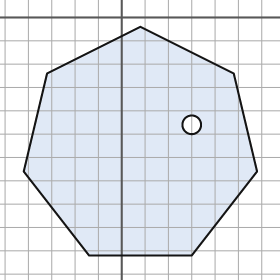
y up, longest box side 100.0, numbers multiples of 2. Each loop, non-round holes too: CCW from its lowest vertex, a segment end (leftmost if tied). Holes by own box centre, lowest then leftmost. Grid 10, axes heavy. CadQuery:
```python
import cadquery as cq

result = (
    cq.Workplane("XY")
    .moveTo(-14.0, -102.0)
    .lineTo(30.0, -102.0)
    .lineTo(58.0, -66.0)
    .lineTo(48.0, -24.0)
    .lineTo(8.0, -4.0)
    .lineTo(-32.0, -24.0)
    .lineTo(-42.0, -66.0)
    .close()
    .moveTo(30.0, -46.0)
    .circle(4.0)
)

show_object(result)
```